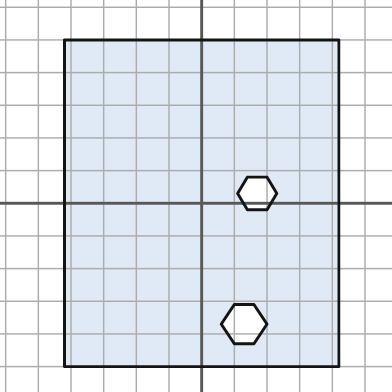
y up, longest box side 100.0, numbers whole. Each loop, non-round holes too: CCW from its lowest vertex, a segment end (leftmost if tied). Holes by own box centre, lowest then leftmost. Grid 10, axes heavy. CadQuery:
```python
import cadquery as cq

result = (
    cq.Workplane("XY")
    .moveTo(-42.0, -50.0)
    .lineTo(42.0, -50.0)
    .lineTo(42.0, 50.0)
    .lineTo(-42.0, 50.0)
    .close()
    .moveTo(10.0, -43.0)
    .lineTo(16.0, -43.0)
    .lineTo(20.0, -37.0)
    .lineTo(16.0, -31.0)
    .lineTo(10.0, -31.0)
    .lineTo(6.0, -37.0)
    .close()
    .moveTo(14.0, -2.0)
    .lineTo(20.0, -2.0)
    .lineTo(23.0, 3.0)
    .lineTo(20.0, 8.0)
    .lineTo(14.0, 8.0)
    .lineTo(11.0, 3.0)
    .close()
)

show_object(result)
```